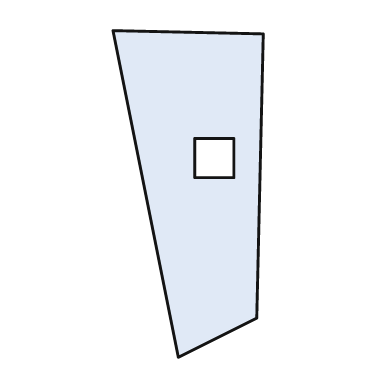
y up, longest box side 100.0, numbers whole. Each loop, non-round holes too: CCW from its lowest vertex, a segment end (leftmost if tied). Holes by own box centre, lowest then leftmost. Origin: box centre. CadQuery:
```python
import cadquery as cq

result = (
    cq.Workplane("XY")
    .moveTo(-3.0, -50.0)
    .lineTo(21.0, -38.0)
    .lineTo(23.0, 49.0)
    .lineTo(-23.0, 50.0)
    .close()
    .moveTo(2.0, 5.0)
    .lineTo(14.0, 5.0)
    .lineTo(14.0, 17.0)
    .lineTo(2.0, 17.0)
    .close()
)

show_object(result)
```